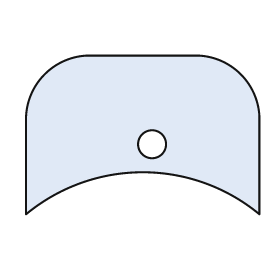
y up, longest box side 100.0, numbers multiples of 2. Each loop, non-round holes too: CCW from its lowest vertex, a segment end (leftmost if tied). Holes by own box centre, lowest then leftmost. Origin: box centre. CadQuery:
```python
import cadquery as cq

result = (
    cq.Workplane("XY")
    .moveTo(-50.0, -34.0)
    .threePointArc((0.0, -16.0), (50.0, -34.0))
    .lineTo(50.0, 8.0)
    .threePointArc((42.0, 26.0), (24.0, 34.0))
    .lineTo(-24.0, 34.0)
    .threePointArc((-42.0, 26.0), (-50.0, 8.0))
    .close()
    .moveTo(4.0, -4.0)
    .circle(6.0)
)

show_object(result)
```